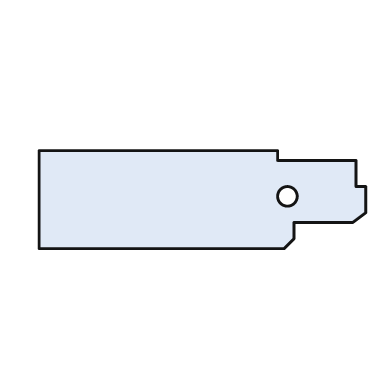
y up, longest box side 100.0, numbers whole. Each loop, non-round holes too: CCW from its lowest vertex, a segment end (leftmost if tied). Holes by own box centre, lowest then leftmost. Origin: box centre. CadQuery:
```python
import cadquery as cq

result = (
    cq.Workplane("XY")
    .moveTo(-50.0, -15.0)
    .lineTo(25.0, -15.0)
    .lineTo(28.0, -12.0)
    .lineTo(28.0, -7.0)
    .lineTo(46.0, -7.0)
    .lineTo(50.0, -4.0)
    .lineTo(50.0, 4.0)
    .lineTo(47.0, 4.0)
    .lineTo(47.0, 12.0)
    .lineTo(23.0, 12.0)
    .lineTo(23.0, 15.0)
    .lineTo(-50.0, 15.0)
    .close()
    .moveTo(26.0, 1.0)
    .circle(3.0)
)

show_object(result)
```